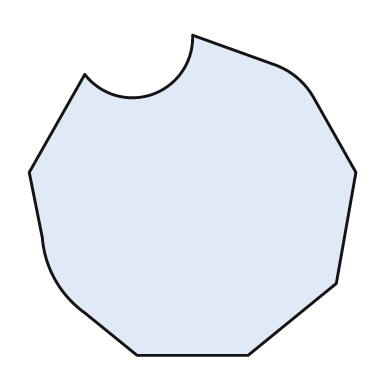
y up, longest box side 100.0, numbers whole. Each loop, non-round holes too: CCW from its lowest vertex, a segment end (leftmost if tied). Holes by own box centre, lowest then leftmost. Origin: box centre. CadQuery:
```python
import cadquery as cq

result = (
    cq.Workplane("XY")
    .moveTo(-17.0, -49.0)
    .lineTo(17.0, -49.0)
    .lineTo(44.0, -27.0)
    .lineTo(50.0, 7.0)
    .lineTo(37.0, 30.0)
    .threePointArc((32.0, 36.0), (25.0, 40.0))
    .lineTo(0.0, 49.0)
    .threePointArc((-12.0, 31.0), (-33.0, 37.0))
    .lineTo(-50.0, 7.0)
    .lineTo(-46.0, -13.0)
    .threePointArc((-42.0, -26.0), (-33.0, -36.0))
    .close()
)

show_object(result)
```